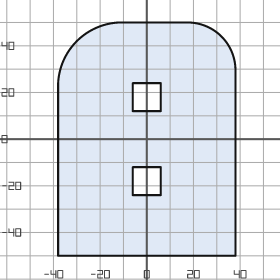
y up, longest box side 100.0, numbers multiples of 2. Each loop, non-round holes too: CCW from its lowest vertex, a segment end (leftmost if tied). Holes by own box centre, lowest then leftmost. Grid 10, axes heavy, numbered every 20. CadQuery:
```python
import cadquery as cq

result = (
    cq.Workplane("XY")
    .moveTo(-38.0, -50.0)
    .lineTo(38.0, -50.0)
    .lineTo(38.0, 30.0)
    .threePointArc((32.0, 44.0), (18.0, 50.0))
    .lineTo(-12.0, 50.0)
    .threePointArc((-30.0, 42.0), (-38.0, 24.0))
    .close()
    .moveTo(-6.0, -24.0)
    .lineTo(6.0, -24.0)
    .lineTo(6.0, -12.0)
    .lineTo(-6.0, -12.0)
    .close()
    .moveTo(-6.0, 12.0)
    .lineTo(6.0, 12.0)
    .lineTo(6.0, 24.0)
    .lineTo(-6.0, 24.0)
    .close()
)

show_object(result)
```